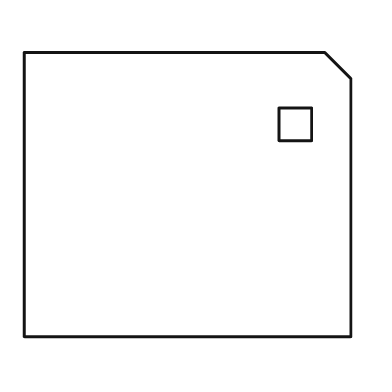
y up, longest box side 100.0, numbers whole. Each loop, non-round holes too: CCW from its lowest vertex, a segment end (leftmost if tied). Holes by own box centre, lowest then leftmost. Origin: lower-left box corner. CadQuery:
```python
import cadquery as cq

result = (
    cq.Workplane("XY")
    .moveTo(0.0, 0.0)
    .lineTo(100.0, 0.0)
    .lineTo(100.0, 79.0)
    .lineTo(92.0, 87.0)
    .lineTo(0.0, 87.0)
    .close()
    .moveTo(78.0, 60.0)
    .lineTo(88.0, 60.0)
    .lineTo(88.0, 70.0)
    .lineTo(78.0, 70.0)
    .close()
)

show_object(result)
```